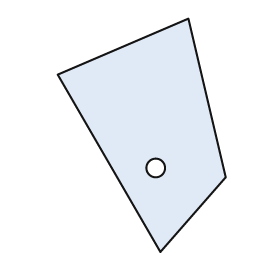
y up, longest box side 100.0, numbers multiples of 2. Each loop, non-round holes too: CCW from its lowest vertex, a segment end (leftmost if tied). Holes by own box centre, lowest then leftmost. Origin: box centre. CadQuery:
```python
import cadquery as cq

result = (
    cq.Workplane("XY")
    .moveTo(8.0, -50.0)
    .lineTo(36.0, -18.0)
    .lineTo(20.0, 50.0)
    .lineTo(-36.0, 26.0)
    .close()
    .moveTo(6.0, -14.0)
    .circle(4.0)
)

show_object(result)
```